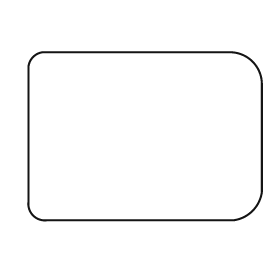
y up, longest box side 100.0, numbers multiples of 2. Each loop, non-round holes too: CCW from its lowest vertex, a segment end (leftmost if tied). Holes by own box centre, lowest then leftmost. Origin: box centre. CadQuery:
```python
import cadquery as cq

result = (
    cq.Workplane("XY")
    .moveTo(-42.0, -36.0)
    .lineTo(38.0, -36.0)
    .threePointArc((46.0, -32.0), (50.0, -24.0))
    .lineTo(50.0, 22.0)
    .threePointArc((46.0, 32.0), (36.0, 36.0))
    .lineTo(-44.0, 36.0)
    .threePointArc((-48.0, 34.0), (-50.0, 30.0))
    .lineTo(-50.0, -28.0)
    .threePointArc((-48.0, -34.0), (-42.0, -36.0))
    .close()
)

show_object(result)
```